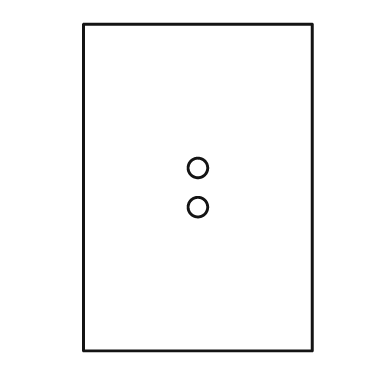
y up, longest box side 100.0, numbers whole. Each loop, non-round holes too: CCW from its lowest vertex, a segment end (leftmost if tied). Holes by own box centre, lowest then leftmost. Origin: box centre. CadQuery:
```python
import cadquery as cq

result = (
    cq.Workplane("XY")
    .moveTo(-35.0, -50.0)
    .lineTo(35.0, -50.0)
    .lineTo(35.0, 50.0)
    .lineTo(-35.0, 50.0)
    .close()
    .moveTo(0.0, -6.0)
    .circle(3.0)
    .moveTo(0.0, 6.0)
    .circle(3.0)
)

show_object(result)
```